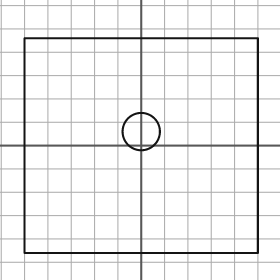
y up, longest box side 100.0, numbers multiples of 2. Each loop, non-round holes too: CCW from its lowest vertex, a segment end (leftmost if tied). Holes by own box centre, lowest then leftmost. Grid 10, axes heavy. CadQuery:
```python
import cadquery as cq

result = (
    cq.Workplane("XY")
    .moveTo(-50.0, -46.0)
    .lineTo(50.0, -46.0)
    .lineTo(50.0, 46.0)
    .lineTo(-50.0, 46.0)
    .close()
    .moveTo(0.0, 6.0)
    .circle(8.0)
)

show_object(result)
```